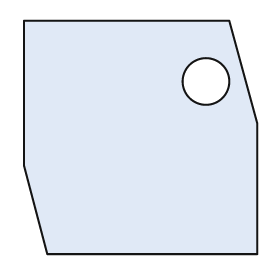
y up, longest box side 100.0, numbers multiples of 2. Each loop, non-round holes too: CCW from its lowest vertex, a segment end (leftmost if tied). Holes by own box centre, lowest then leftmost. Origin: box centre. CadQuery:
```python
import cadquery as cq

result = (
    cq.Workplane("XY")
    .moveTo(-40.0, -50.0)
    .lineTo(50.0, -50.0)
    .lineTo(50.0, 6.0)
    .lineTo(38.0, 50.0)
    .lineTo(-50.0, 50.0)
    .lineTo(-50.0, -12.0)
    .close()
    .moveTo(28.0, 24.0)
    .circle(10.0)
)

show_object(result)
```